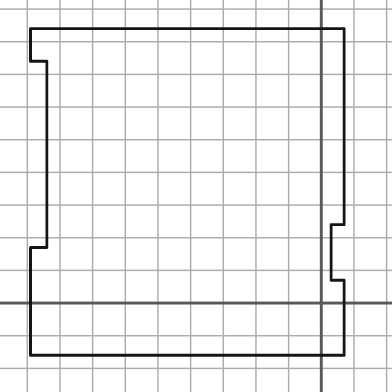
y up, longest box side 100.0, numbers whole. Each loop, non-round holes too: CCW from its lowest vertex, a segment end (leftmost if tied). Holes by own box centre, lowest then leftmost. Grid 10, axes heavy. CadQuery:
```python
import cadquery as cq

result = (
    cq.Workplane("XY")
    .moveTo(-89.0, -16.0)
    .lineTo(7.0, -16.0)
    .lineTo(7.0, 7.0)
    .lineTo(3.0, 7.0)
    .lineTo(3.0, 24.0)
    .lineTo(7.0, 24.0)
    .lineTo(7.0, 84.0)
    .lineTo(-89.0, 84.0)
    .lineTo(-89.0, 74.0)
    .lineTo(-84.0, 74.0)
    .lineTo(-84.0, 17.0)
    .lineTo(-89.0, 17.0)
    .close()
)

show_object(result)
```